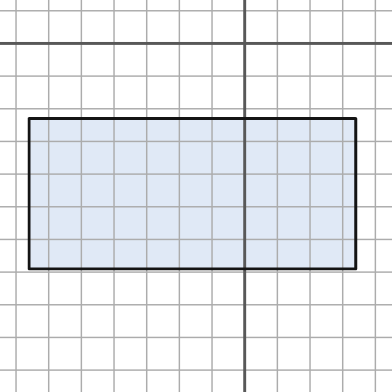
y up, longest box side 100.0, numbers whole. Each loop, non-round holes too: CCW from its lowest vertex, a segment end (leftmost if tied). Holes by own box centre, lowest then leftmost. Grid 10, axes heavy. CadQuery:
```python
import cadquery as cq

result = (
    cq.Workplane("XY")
    .moveTo(-66.0, -69.0)
    .lineTo(34.0, -69.0)
    .lineTo(34.0, -23.0)
    .lineTo(-66.0, -23.0)
    .close()
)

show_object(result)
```